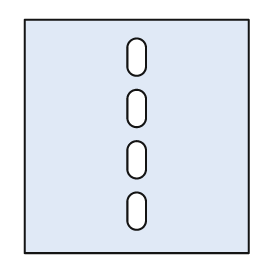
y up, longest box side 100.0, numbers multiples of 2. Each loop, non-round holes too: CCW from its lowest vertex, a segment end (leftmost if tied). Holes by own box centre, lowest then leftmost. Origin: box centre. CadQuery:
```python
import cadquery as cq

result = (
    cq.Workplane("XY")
    .moveTo(-48.0, -50.0)
    .lineTo(48.0, -50.0)
    .lineTo(48.0, 50.0)
    .lineTo(-48.0, 50.0)
    .close()
    .moveTo(-4.0, -36.0)
    .threePointArc((0.0, -40.0), (4.0, -36.0))
    .lineTo(4.0, -28.0)
    .threePointArc((0.0, -24.0), (-4.0, -28.0))
    .close()
    .moveTo(-4.0, -14.0)
    .threePointArc((0.0, -18.0), (4.0, -14.0))
    .lineTo(4.0, -6.0)
    .threePointArc((0.0, -2.0), (-4.0, -6.0))
    .close()
    .moveTo(-4.0, 8.0)
    .threePointArc((0.0, 4.0), (4.0, 8.0))
    .lineTo(4.0, 16.0)
    .threePointArc((0.0, 20.0), (-4.0, 16.0))
    .close()
    .moveTo(-4.0, 30.0)
    .threePointArc((0.0, 26.0), (4.0, 30.0))
    .lineTo(4.0, 38.0)
    .threePointArc((0.0, 42.0), (-4.0, 38.0))
    .close()
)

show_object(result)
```